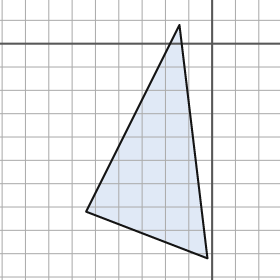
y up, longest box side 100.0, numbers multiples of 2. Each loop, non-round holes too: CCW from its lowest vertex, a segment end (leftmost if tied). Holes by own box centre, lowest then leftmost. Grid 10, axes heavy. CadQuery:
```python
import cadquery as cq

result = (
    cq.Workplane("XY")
    .moveTo(-2.0, -92.0)
    .lineTo(-14.0, 8.0)
    .lineTo(-54.0, -72.0)
    .close()
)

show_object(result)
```